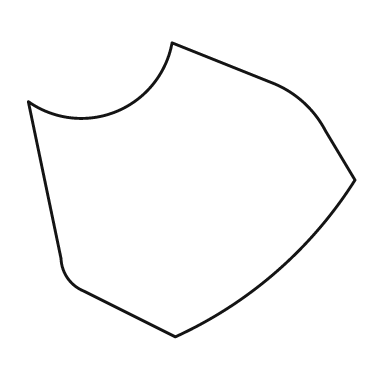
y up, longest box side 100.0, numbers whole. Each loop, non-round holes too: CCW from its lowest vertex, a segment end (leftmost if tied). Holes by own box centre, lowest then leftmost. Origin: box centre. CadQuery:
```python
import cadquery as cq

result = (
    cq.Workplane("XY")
    .moveTo(-5.0, -45.0)
    .threePointArc((26.0, -25.0), (50.0, 3.0))
    .lineTo(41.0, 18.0)
    .threePointArc((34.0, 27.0), (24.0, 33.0))
    .lineTo(-6.0, 45.0)
    .threePointArc((-23.0, 24.0), (-50.0, 27.0))
    .lineTo(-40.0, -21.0)
    .threePointArc((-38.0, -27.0), (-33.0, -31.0))
    .close()
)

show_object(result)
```